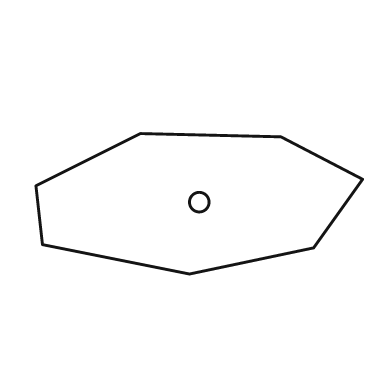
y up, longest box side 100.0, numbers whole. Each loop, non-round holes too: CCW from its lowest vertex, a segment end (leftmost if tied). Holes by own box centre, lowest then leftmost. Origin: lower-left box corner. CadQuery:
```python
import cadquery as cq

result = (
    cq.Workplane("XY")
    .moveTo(47.0, 0.0)
    .lineTo(85.0, 8.0)
    .lineTo(100.0, 29.0)
    .lineTo(75.0, 42.0)
    .lineTo(32.0, 43.0)
    .lineTo(0.0, 27.0)
    .lineTo(2.0, 9.0)
    .close()
    .moveTo(50.0, 22.0)
    .circle(3.0)
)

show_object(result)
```